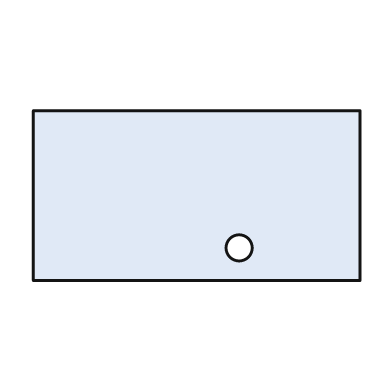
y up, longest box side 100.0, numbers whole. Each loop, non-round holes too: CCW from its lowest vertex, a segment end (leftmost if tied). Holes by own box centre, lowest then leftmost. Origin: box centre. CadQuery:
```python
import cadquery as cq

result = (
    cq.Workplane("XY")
    .moveTo(-50.0, -26.0)
    .lineTo(50.0, -26.0)
    .lineTo(50.0, 26.0)
    .lineTo(-50.0, 26.0)
    .close()
    .moveTo(13.0, -16.0)
    .circle(4.0)
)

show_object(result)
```